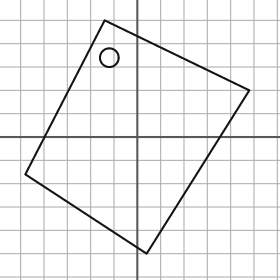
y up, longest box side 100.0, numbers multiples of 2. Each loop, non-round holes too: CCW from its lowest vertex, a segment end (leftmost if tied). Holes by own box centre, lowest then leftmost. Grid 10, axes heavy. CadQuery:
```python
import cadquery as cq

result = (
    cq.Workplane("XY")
    .moveTo(4.0, -50.0)
    .lineTo(48.0, 20.0)
    .lineTo(-14.0, 50.0)
    .lineTo(-48.0, -16.0)
    .close()
    .moveTo(-12.0, 34.0)
    .circle(4.0)
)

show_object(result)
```